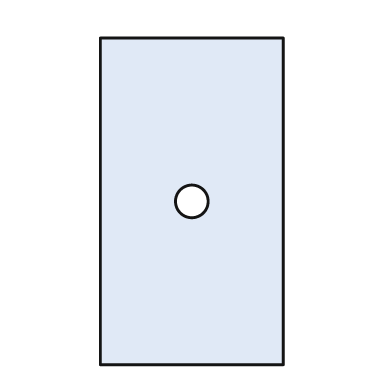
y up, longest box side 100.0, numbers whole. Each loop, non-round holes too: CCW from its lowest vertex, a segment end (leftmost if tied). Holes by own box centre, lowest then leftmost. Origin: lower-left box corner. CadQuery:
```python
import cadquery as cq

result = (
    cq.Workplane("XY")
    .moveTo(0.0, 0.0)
    .lineTo(56.0, 0.0)
    .lineTo(56.0, 100.0)
    .lineTo(0.0, 100.0)
    .close()
    .moveTo(28.0, 50.0)
    .circle(5.0)
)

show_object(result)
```